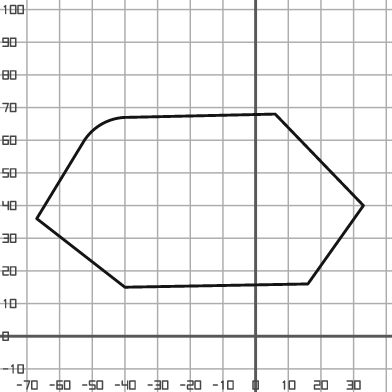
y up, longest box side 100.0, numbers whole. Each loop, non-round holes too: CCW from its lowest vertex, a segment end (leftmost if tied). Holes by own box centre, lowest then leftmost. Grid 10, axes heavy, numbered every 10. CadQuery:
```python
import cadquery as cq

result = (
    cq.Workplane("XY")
    .moveTo(-40.0, 15.0)
    .lineTo(16.0, 16.0)
    .lineTo(33.0, 40.0)
    .lineTo(6.0, 68.0)
    .lineTo(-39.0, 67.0)
    .threePointArc((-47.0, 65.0), (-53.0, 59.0))
    .lineTo(-67.0, 36.0)
    .close()
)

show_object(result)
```